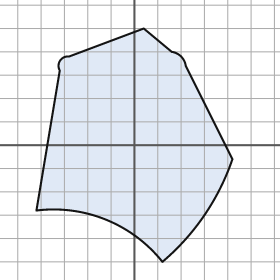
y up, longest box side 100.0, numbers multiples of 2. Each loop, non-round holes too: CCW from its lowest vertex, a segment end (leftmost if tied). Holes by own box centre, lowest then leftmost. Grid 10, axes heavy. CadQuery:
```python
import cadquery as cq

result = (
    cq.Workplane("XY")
    .moveTo(12.0, -50.0)
    .threePointArc((30.0, -30.0), (42.0, -6.0))
    .lineTo(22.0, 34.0)
    .threePointArc((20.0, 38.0), (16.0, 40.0))
    .lineTo(4.0, 50.0)
    .lineTo(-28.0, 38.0)
    .threePointArc((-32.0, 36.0), (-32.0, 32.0))
    .lineTo(-42.0, -28.0)
    .threePointArc((-12.0, -32.0), (12.0, -50.0))
    .close()
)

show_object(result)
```